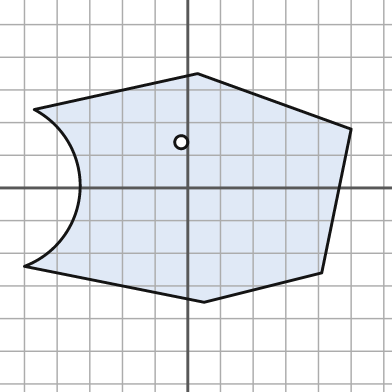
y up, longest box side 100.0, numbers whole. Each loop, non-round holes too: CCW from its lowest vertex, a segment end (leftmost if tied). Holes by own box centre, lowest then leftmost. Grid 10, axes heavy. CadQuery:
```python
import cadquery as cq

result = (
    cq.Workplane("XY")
    .moveTo(5.0, -35.0)
    .lineTo(41.0, -26.0)
    .lineTo(50.0, 18.0)
    .lineTo(3.0, 35.0)
    .lineTo(-47.0, 24.0)
    .threePointArc((-33.0, -1.0), (-50.0, -24.0))
    .close()
    .moveTo(-2.0, 14.0)
    .circle(2.0)
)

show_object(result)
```